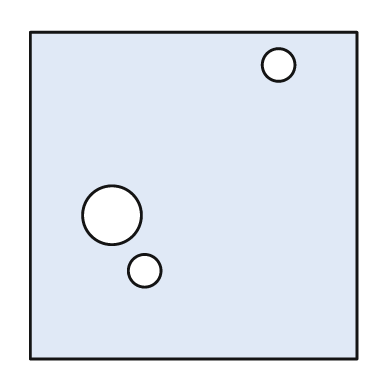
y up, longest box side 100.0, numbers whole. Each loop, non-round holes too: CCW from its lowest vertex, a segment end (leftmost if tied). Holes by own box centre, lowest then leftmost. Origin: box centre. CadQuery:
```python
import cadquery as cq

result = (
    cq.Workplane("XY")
    .moveTo(-50.0, -50.0)
    .lineTo(50.0, -50.0)
    .lineTo(50.0, 50.0)
    .lineTo(-50.0, 50.0)
    .close()
    .moveTo(-15.0, -23.0)
    .circle(5.0)
    .moveTo(-25.0, -6.0)
    .circle(9.0)
    .moveTo(26.0, 40.0)
    .circle(5.0)
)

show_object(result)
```